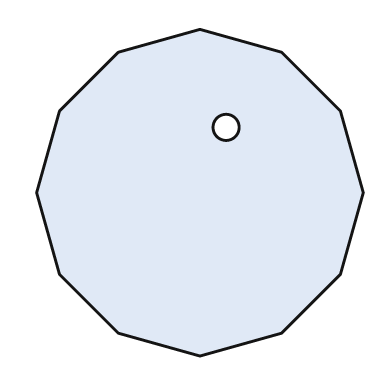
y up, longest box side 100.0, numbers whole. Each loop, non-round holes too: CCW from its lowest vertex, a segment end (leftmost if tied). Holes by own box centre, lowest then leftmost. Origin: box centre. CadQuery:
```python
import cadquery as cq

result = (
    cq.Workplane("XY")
    .moveTo(0.0, -50.0)
    .lineTo(25.0, -43.0)
    .lineTo(43.0, -25.0)
    .lineTo(50.0, 0.0)
    .lineTo(43.0, 25.0)
    .lineTo(25.0, 43.0)
    .lineTo(0.0, 50.0)
    .lineTo(-25.0, 43.0)
    .lineTo(-43.0, 25.0)
    .lineTo(-50.0, 0.0)
    .lineTo(-43.0, -25.0)
    .lineTo(-25.0, -43.0)
    .close()
    .moveTo(8.0, 20.0)
    .circle(4.0)
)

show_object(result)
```